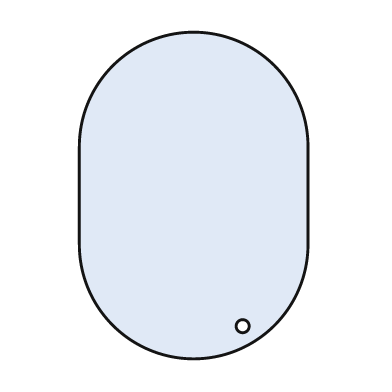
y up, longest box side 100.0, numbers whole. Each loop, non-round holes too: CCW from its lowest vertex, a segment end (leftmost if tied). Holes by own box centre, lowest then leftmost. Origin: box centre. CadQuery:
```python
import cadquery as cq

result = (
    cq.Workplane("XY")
    .moveTo(-35.0, -15.0)
    .threePointArc((0.0, -50.0), (35.0, -15.0))
    .lineTo(35.0, 15.0)
    .threePointArc((0.0, 50.0), (-35.0, 15.0))
    .close()
    .moveTo(15.0, -40.0)
    .circle(2.0)
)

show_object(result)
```